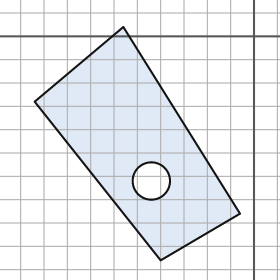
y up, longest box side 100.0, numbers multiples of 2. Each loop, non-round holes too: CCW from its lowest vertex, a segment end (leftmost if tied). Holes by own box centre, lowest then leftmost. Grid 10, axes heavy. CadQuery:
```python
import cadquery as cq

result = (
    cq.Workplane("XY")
    .moveTo(-40.0, -96.0)
    .lineTo(-6.0, -76.0)
    .lineTo(-56.0, 4.0)
    .lineTo(-94.0, -28.0)
    .close()
    .moveTo(-44.0, -62.0)
    .circle(8.0)
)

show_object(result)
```